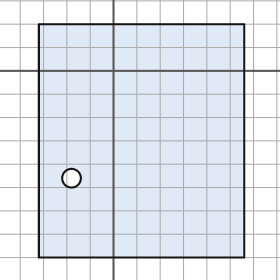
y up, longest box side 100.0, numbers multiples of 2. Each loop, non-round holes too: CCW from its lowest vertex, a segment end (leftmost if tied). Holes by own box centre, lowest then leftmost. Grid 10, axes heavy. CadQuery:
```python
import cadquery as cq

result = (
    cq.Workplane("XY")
    .moveTo(-32.0, -80.0)
    .lineTo(56.0, -80.0)
    .lineTo(56.0, 20.0)
    .lineTo(-32.0, 20.0)
    .close()
    .moveTo(-18.0, -46.0)
    .circle(4.0)
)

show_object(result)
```